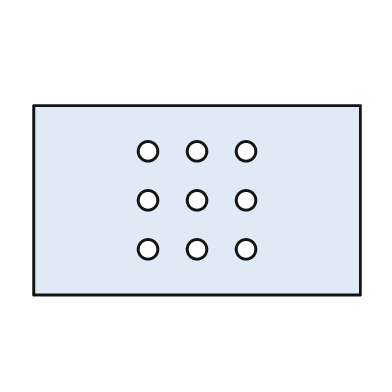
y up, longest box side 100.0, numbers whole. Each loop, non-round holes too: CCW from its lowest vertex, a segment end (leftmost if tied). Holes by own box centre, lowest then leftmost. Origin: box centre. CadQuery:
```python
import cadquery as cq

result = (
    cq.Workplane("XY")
    .moveTo(-50.0, -29.0)
    .lineTo(50.0, -29.0)
    .lineTo(50.0, 29.0)
    .lineTo(-50.0, 29.0)
    .close()
    .moveTo(-15.0, -15.0)
    .circle(3.0)
    .moveTo(0.0, -15.0)
    .circle(3.0)
    .moveTo(15.0, -15.0)
    .circle(3.0)
    .moveTo(-15.0, 0.0)
    .circle(3.0)
    .moveTo(0.0, 0.0)
    .circle(3.0)
    .moveTo(15.0, 0.0)
    .circle(3.0)
    .moveTo(-15.0, 15.0)
    .circle(3.0)
    .moveTo(0.0, 15.0)
    .circle(3.0)
    .moveTo(15.0, 15.0)
    .circle(3.0)
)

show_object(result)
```